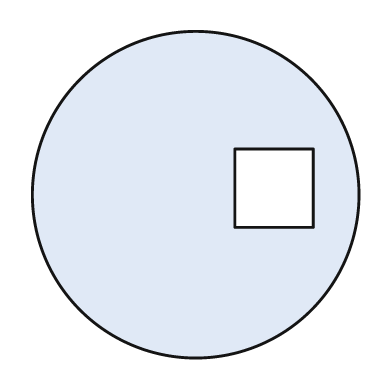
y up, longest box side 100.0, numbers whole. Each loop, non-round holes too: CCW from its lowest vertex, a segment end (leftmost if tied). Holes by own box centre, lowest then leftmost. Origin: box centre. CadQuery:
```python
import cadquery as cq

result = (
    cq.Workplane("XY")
    .moveTo(0.0, 0.0)
    .circle(50.0)
    .moveTo(12.0, -10.0)
    .lineTo(36.0, -10.0)
    .lineTo(36.0, 14.0)
    .lineTo(12.0, 14.0)
    .close()
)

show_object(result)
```